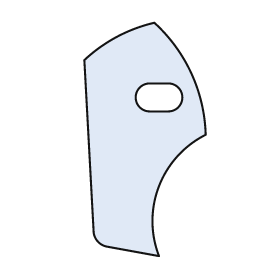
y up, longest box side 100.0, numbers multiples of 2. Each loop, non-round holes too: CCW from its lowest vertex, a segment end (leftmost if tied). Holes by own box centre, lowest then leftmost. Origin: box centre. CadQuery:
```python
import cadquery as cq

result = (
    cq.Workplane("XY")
    .moveTo(6.0, -50.0)
    .threePointArc((6.0, -20.0), (26.0, 2.0))
    .threePointArc((20.0, 28.0), (4.0, 50.0))
    .threePointArc((-12.0, 44.0), (-26.0, 34.0))
    .lineTo(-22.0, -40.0)
    .threePointArc((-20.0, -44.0), (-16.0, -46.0))
    .close()
    .moveTo(2.0, 12.0)
    .lineTo(10.0, 12.0)
    .threePointArc((16.0, 18.0), (10.0, 24.0))
    .lineTo(2.0, 24.0)
    .threePointArc((-4.0, 18.0), (2.0, 12.0))
    .close()
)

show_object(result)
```